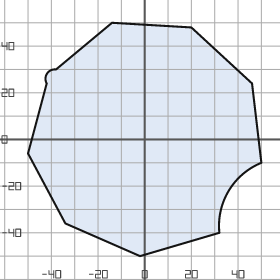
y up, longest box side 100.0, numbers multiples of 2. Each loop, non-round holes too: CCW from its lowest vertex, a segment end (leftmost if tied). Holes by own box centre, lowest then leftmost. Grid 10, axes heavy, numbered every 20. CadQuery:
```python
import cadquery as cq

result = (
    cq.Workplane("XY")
    .moveTo(-2.0, -50.0)
    .lineTo(32.0, -40.0)
    .threePointArc((36.0, -22.0), (50.0, -10.0))
    .lineTo(46.0, 24.0)
    .lineTo(20.0, 48.0)
    .lineTo(-14.0, 50.0)
    .lineTo(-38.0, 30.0)
    .threePointArc((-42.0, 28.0), (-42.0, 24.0))
    .lineTo(-50.0, -6.0)
    .lineTo(-34.0, -36.0)
    .close()
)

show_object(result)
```